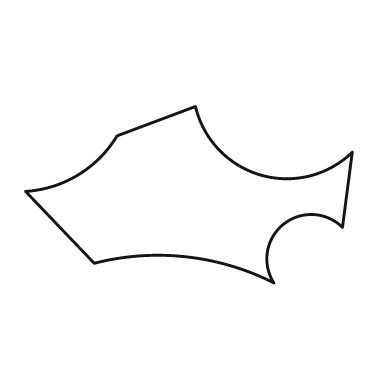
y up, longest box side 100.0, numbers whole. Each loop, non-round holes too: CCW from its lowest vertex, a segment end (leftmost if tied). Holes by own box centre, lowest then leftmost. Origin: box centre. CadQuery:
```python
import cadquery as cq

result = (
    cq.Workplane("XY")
    .moveTo(26.0, -27.0)
    .threePointArc((29.0, -9.0), (47.0, -10.0))
    .lineTo(50.0, 13.0)
    .threePointArc((22.0, 6.0), (2.0, 27.0))
    .lineTo(-22.0, 18.0)
    .threePointArc((-34.0, 6.0), (-50.0, 1.0))
    .lineTo(-29.0, -21.0)
    .threePointArc((-1.0, -19.0), (26.0, -27.0))
    .close()
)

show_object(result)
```